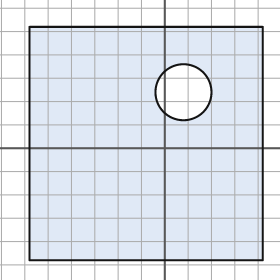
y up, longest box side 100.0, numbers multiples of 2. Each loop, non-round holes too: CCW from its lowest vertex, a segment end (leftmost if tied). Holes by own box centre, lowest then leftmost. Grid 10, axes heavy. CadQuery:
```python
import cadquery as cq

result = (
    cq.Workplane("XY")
    .moveTo(-58.0, -48.0)
    .lineTo(42.0, -48.0)
    .lineTo(42.0, 52.0)
    .lineTo(-58.0, 52.0)
    .close()
    .moveTo(8.0, 24.0)
    .circle(12.0)
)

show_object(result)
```